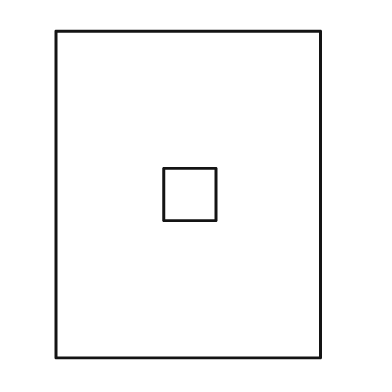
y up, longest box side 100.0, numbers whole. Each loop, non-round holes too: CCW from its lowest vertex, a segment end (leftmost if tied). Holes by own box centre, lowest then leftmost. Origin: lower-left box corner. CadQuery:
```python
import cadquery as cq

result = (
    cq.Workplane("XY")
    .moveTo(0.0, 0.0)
    .lineTo(81.0, 0.0)
    .lineTo(81.0, 100.0)
    .lineTo(0.0, 100.0)
    .close()
    .moveTo(33.0, 42.0)
    .lineTo(49.0, 42.0)
    .lineTo(49.0, 58.0)
    .lineTo(33.0, 58.0)
    .close()
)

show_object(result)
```